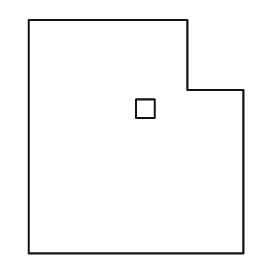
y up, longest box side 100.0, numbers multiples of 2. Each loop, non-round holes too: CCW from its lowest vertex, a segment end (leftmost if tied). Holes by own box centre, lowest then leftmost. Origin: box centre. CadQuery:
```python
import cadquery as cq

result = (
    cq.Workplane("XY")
    .moveTo(-46.0, -50.0)
    .lineTo(46.0, -50.0)
    .lineTo(46.0, 20.0)
    .lineTo(22.0, 20.0)
    .lineTo(22.0, 50.0)
    .lineTo(-46.0, 50.0)
    .close()
    .moveTo(0.0, 8.0)
    .lineTo(8.0, 8.0)
    .lineTo(8.0, 16.0)
    .lineTo(0.0, 16.0)
    .close()
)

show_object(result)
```